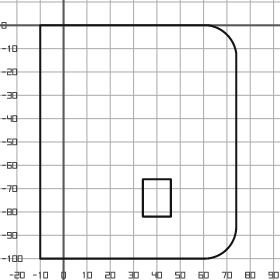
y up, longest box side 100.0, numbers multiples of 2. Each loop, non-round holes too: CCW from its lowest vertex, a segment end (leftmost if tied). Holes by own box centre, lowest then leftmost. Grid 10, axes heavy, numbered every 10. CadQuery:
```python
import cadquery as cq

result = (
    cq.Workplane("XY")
    .moveTo(-10.0, -100.0)
    .lineTo(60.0, -100.0)
    .threePointArc((70.0, -96.0), (74.0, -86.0))
    .lineTo(74.0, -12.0)
    .threePointArc((70.0, -4.0), (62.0, 0.0))
    .lineTo(-10.0, 0.0)
    .close()
    .moveTo(34.0, -82.0)
    .lineTo(46.0, -82.0)
    .lineTo(46.0, -66.0)
    .lineTo(34.0, -66.0)
    .close()
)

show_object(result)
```